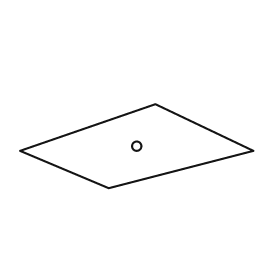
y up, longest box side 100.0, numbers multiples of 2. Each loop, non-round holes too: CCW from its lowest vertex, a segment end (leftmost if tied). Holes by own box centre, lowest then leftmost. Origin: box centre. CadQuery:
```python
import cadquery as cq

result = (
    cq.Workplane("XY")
    .moveTo(-12.0, -18.0)
    .lineTo(50.0, -2.0)
    .lineTo(8.0, 18.0)
    .lineTo(-50.0, -2.0)
    .close()
    .moveTo(0.0, 0.0)
    .circle(2.0)
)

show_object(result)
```